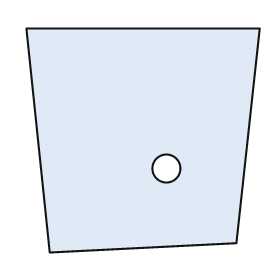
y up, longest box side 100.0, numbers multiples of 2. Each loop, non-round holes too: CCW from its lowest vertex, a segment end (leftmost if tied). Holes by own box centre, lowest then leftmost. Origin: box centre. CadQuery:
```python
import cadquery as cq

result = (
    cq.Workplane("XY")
    .moveTo(-40.0, -48.0)
    .lineTo(40.0, -44.0)
    .lineTo(50.0, 48.0)
    .lineTo(-50.0, 48.0)
    .close()
    .moveTo(10.0, -12.0)
    .circle(6.0)
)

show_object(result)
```